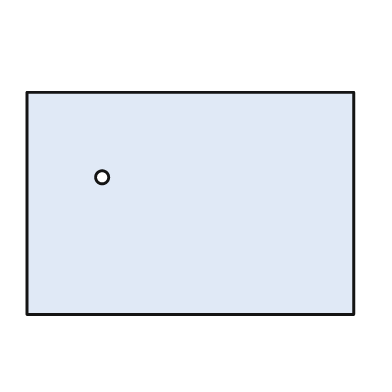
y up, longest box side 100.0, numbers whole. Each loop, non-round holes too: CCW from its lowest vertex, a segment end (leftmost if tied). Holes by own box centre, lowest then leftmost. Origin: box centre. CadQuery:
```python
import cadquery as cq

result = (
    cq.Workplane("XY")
    .moveTo(-50.0, -34.0)
    .lineTo(50.0, -34.0)
    .lineTo(50.0, 34.0)
    .lineTo(-50.0, 34.0)
    .close()
    .moveTo(-27.0, 8.0)
    .circle(2.0)
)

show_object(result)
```